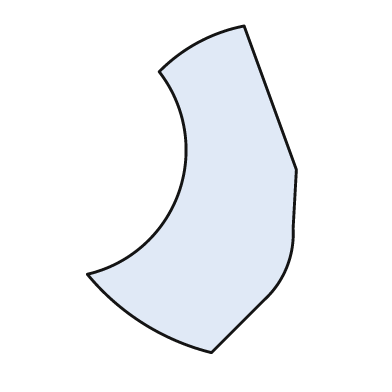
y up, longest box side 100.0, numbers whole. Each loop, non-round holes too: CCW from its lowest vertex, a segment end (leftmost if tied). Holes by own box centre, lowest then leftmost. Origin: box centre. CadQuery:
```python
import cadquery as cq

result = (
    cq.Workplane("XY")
    .moveTo(6.0, -50.0)
    .lineTo(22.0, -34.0)
    .threePointArc((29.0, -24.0), (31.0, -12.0))
    .lineTo(32.0, 6.0)
    .lineTo(16.0, 50.0)
    .threePointArc((2.0, 45.0), (-10.0, 36.0))
    .threePointArc((-4.0, -1.0), (-32.0, -26.0))
    .threePointArc((-15.0, -41.0), (6.0, -50.0))
    .close()
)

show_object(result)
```